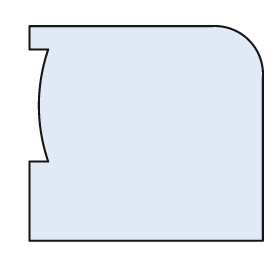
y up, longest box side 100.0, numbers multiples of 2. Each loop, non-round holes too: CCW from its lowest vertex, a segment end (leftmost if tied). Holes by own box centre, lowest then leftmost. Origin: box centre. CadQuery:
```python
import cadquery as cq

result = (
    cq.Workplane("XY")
    .moveTo(-50.0, -46.0)
    .lineTo(50.0, -46.0)
    .lineTo(50.0, 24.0)
    .threePointArc((44.0, 40.0), (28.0, 46.0))
    .lineTo(-50.0, 46.0)
    .lineTo(-50.0, 36.0)
    .lineTo(-42.0, 36.0)
    .threePointArc((-46.0, 12.0), (-42.0, -12.0))
    .lineTo(-50.0, -12.0)
    .close()
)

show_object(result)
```